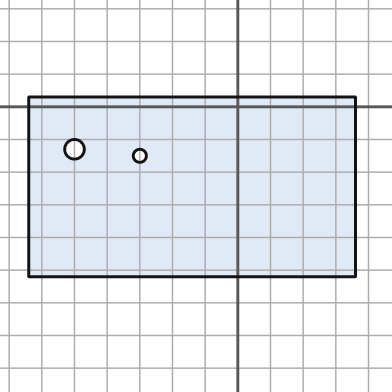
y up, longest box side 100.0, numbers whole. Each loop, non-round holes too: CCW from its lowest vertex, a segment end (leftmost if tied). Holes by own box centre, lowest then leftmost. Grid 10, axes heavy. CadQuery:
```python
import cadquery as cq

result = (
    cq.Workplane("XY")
    .moveTo(-64.0, -52.0)
    .lineTo(36.0, -52.0)
    .lineTo(36.0, 3.0)
    .lineTo(-64.0, 3.0)
    .close()
    .moveTo(-30.0, -15.0)
    .circle(2.0)
    .moveTo(-50.0, -13.0)
    .circle(3.0)
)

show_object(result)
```